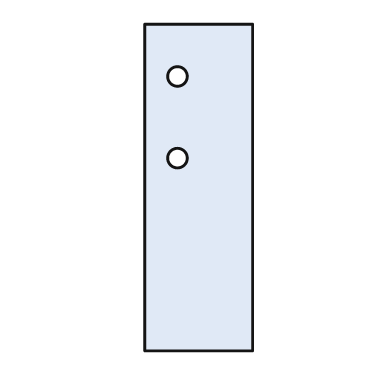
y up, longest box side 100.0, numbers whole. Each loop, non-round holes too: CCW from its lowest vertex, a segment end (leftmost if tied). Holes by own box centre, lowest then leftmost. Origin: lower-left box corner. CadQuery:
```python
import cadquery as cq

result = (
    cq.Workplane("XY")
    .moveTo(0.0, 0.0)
    .lineTo(33.0, 0.0)
    .lineTo(33.0, 100.0)
    .lineTo(0.0, 100.0)
    .close()
    .moveTo(10.0, 59.0)
    .circle(3.0)
    .moveTo(10.0, 84.0)
    .circle(3.0)
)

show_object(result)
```